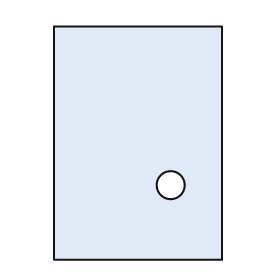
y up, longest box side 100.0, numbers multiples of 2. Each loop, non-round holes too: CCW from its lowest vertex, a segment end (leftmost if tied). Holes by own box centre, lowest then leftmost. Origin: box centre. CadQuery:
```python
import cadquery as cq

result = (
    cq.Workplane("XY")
    .moveTo(-36.0, -50.0)
    .lineTo(36.0, -50.0)
    .lineTo(36.0, 50.0)
    .lineTo(-36.0, 50.0)
    .close()
    .moveTo(14.0, -18.0)
    .circle(6.0)
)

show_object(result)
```